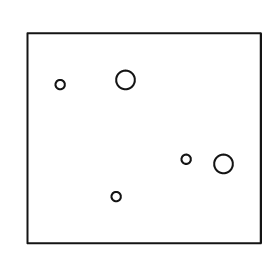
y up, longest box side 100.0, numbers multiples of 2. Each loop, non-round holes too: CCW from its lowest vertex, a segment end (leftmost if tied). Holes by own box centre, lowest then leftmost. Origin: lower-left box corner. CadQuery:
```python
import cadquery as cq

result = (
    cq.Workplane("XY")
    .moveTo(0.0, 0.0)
    .lineTo(100.0, 0.0)
    .lineTo(100.0, 90.0)
    .lineTo(0.0, 90.0)
    .close()
    .moveTo(38.0, 20.0)
    .circle(2.0)
    .moveTo(84.0, 34.0)
    .circle(4.0)
    .moveTo(68.0, 36.0)
    .circle(2.0)
    .moveTo(14.0, 68.0)
    .circle(2.0)
    .moveTo(42.0, 70.0)
    .circle(4.0)
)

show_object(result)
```